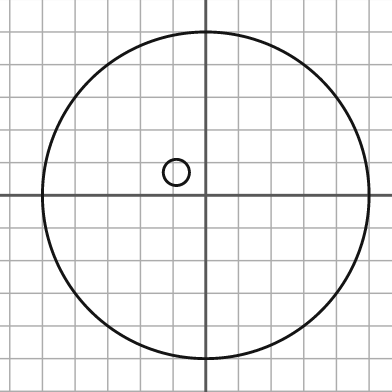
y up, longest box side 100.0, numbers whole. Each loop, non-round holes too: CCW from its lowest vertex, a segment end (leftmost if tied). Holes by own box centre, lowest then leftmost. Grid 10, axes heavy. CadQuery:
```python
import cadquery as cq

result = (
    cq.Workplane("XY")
    .moveTo(0.0, 0.0)
    .circle(50.0)
    .moveTo(-9.0, 7.0)
    .circle(4.0)
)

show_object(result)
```